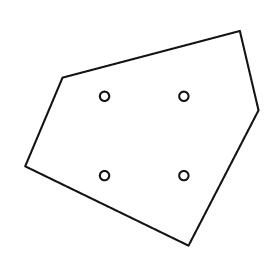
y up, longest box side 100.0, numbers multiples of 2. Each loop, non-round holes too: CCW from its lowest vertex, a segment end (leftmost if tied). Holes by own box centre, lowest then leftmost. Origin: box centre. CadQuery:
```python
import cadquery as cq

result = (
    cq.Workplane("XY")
    .moveTo(20.0, -46.0)
    .lineTo(50.0, 12.0)
    .lineTo(42.0, 46.0)
    .lineTo(-34.0, 26.0)
    .lineTo(-50.0, -12.0)
    .close()
    .moveTo(-16.0, -16.0)
    .circle(2.0)
    .moveTo(18.0, -16.0)
    .circle(2.0)
    .moveTo(-16.0, 18.0)
    .circle(2.0)
    .moveTo(18.0, 18.0)
    .circle(2.0)
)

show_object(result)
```